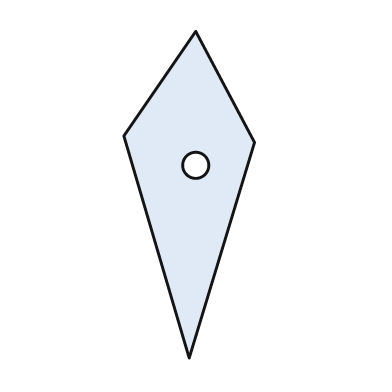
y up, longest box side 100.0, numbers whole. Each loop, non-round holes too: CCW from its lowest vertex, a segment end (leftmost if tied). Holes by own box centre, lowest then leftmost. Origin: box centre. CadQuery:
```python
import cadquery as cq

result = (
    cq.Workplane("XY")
    .moveTo(0.0, -50.0)
    .lineTo(20.0, 16.0)
    .lineTo(2.0, 50.0)
    .lineTo(-20.0, 18.0)
    .close()
    .moveTo(2.0, 9.0)
    .circle(4.0)
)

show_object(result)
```